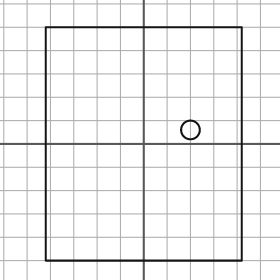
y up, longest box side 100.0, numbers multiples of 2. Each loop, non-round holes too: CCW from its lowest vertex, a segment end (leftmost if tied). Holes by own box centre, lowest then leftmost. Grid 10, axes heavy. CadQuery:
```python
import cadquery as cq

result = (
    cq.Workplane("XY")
    .moveTo(-42.0, -50.0)
    .lineTo(42.0, -50.0)
    .lineTo(42.0, 50.0)
    .lineTo(-42.0, 50.0)
    .close()
    .moveTo(20.0, 6.0)
    .circle(4.0)
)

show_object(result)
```